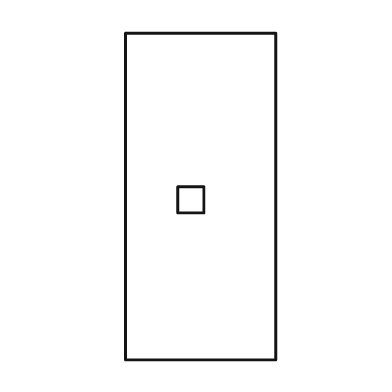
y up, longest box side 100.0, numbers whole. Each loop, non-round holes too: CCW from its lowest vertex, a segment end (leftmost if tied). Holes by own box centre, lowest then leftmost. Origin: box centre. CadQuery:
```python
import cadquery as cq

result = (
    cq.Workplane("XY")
    .moveTo(-23.0, -50.0)
    .lineTo(23.0, -50.0)
    .lineTo(23.0, 50.0)
    .lineTo(-23.0, 50.0)
    .close()
    .moveTo(-7.0, -5.0)
    .lineTo(1.0, -5.0)
    .lineTo(1.0, 3.0)
    .lineTo(-7.0, 3.0)
    .close()
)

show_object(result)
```